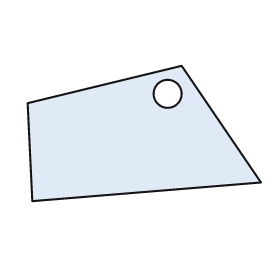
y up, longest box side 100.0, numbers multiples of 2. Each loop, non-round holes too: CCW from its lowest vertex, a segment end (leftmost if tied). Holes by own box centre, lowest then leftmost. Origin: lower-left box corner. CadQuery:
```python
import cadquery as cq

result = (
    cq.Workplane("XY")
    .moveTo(2.0, 0.0)
    .lineTo(100.0, 8.0)
    .lineTo(66.0, 58.0)
    .lineTo(0.0, 42.0)
    .close()
    .moveTo(60.0, 46.0)
    .circle(6.0)
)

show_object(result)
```